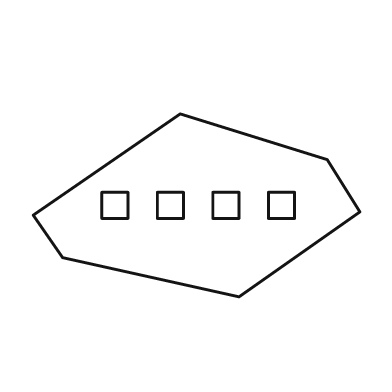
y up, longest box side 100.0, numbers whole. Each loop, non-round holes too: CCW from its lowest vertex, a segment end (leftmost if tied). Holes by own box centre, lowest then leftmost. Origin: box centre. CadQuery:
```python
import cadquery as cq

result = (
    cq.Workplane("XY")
    .moveTo(13.0, -28.0)
    .lineTo(50.0, -2.0)
    .lineTo(40.0, 14.0)
    .lineTo(-5.0, 28.0)
    .lineTo(-50.0, -3.0)
    .lineTo(-41.0, -16.0)
    .close()
    .moveTo(-29.0, -4.0)
    .lineTo(-21.0, -4.0)
    .lineTo(-21.0, 4.0)
    .lineTo(-29.0, 4.0)
    .close()
    .moveTo(-12.0, -4.0)
    .lineTo(-4.0, -4.0)
    .lineTo(-4.0, 4.0)
    .lineTo(-12.0, 4.0)
    .close()
    .moveTo(5.0, -4.0)
    .lineTo(13.0, -4.0)
    .lineTo(13.0, 4.0)
    .lineTo(5.0, 4.0)
    .close()
    .moveTo(22.0, -4.0)
    .lineTo(30.0, -4.0)
    .lineTo(30.0, 4.0)
    .lineTo(22.0, 4.0)
    .close()
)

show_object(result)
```